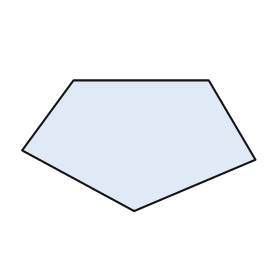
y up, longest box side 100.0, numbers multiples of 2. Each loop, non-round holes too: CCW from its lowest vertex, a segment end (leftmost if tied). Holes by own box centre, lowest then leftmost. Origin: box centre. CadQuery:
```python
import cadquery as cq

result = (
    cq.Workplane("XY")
    .moveTo(-2.0, -28.0)
    .lineTo(50.0, -6.0)
    .lineTo(30.0, 28.0)
    .lineTo(-28.0, 28.0)
    .lineTo(-50.0, -2.0)
    .close()
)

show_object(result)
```